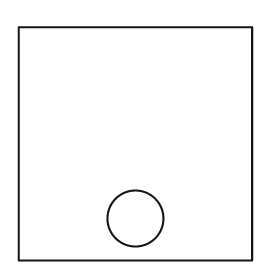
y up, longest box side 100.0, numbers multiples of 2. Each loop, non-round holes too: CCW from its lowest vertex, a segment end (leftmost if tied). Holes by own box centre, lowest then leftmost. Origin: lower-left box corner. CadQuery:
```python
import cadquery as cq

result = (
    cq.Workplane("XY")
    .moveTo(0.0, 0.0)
    .lineTo(100.0, 0.0)
    .lineTo(100.0, 100.0)
    .lineTo(0.0, 100.0)
    .close()
    .moveTo(50.0, 18.0)
    .circle(12.0)
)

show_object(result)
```